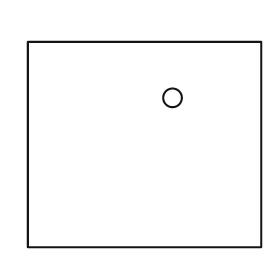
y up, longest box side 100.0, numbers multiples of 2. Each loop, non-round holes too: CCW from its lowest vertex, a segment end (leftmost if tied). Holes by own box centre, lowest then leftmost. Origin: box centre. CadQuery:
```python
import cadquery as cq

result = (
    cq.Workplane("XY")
    .moveTo(-50.0, -44.0)
    .lineTo(50.0, -44.0)
    .lineTo(50.0, 44.0)
    .lineTo(-50.0, 44.0)
    .close()
    .moveTo(12.0, 20.0)
    .circle(4.0)
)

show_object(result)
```